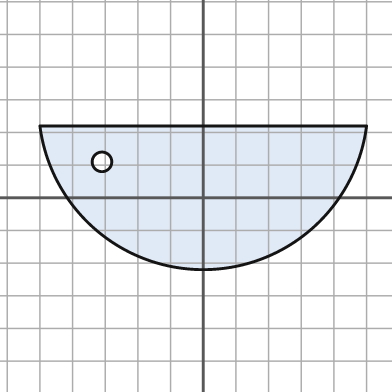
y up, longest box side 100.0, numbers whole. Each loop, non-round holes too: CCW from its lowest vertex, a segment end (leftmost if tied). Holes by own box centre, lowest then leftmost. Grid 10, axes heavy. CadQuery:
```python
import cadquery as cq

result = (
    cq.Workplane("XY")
    .moveTo(-50.0, 22.0)
    .threePointArc((0.0, -22.0), (50.0, 22.0))
    .close()
    .moveTo(-31.0, 11.0)
    .circle(3.0)
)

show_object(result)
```